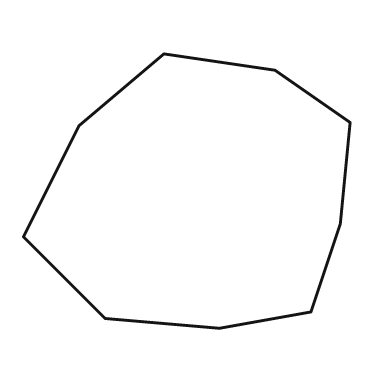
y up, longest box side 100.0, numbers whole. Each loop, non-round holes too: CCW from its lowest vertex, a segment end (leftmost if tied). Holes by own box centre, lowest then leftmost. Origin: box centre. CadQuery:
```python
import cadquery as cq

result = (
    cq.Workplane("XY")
    .moveTo(10.0, -42.0)
    .lineTo(38.0, -37.0)
    .lineTo(47.0, -10.0)
    .lineTo(50.0, 21.0)
    .lineTo(27.0, 37.0)
    .lineTo(-7.0, 42.0)
    .lineTo(-33.0, 20.0)
    .lineTo(-50.0, -14.0)
    .lineTo(-25.0, -39.0)
    .close()
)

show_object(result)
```